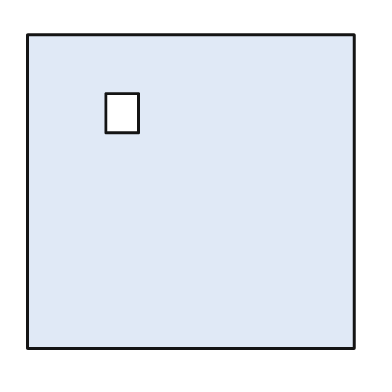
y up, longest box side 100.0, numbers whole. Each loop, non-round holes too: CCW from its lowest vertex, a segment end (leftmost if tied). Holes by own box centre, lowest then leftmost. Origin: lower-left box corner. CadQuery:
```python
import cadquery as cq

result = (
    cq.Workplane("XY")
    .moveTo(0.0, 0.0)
    .lineTo(100.0, 0.0)
    .lineTo(100.0, 96.0)
    .lineTo(0.0, 96.0)
    .close()
    .moveTo(24.0, 66.0)
    .lineTo(34.0, 66.0)
    .lineTo(34.0, 78.0)
    .lineTo(24.0, 78.0)
    .close()
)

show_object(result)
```